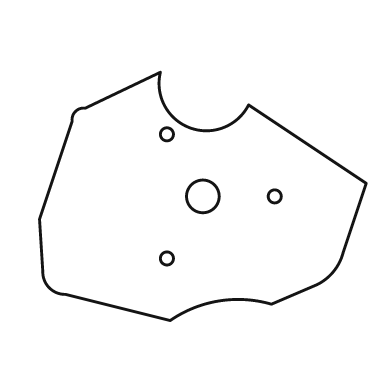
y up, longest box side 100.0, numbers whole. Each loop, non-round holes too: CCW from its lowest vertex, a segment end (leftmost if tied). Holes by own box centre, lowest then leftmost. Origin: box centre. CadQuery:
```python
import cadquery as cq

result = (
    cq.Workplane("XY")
    .moveTo(-10.0, -38.0)
    .threePointArc((5.0, -32.0), (21.0, -33.0))
    .lineTo(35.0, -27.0)
    .threePointArc((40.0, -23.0), (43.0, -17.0))
    .lineTo(50.0, 4.0)
    .lineTo(14.0, 28.0)
    .threePointArc((-4.0, 21.0), (-13.0, 38.0))
    .lineTo(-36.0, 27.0)
    .threePointArc((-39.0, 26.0), (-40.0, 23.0))
    .lineTo(-50.0, -7.0)
    .lineTo(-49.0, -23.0)
    .threePointArc((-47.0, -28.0), (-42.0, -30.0))
    .close()
    .moveTo(-11.0, -19.0)
    .circle(2.0)
    .moveTo(0.0, 0.0)
    .circle(5.0)
    .moveTo(22.0, 0.0)
    .circle(2.0)
    .moveTo(-11.0, 19.0)
    .circle(2.0)
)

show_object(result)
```